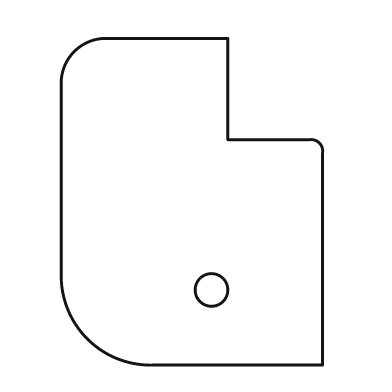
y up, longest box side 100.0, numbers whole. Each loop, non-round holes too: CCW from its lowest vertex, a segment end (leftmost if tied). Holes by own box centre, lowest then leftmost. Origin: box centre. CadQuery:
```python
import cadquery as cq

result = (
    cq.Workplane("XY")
    .moveTo(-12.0, -50.0)
    .lineTo(40.0, -50.0)
    .lineTo(40.0, 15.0)
    .threePointArc((39.0, 18.0), (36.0, 19.0))
    .lineTo(11.0, 19.0)
    .lineTo(11.0, 50.0)
    .lineTo(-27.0, 50.0)
    .threePointArc((-36.0, 46.0), (-40.0, 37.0))
    .lineTo(-40.0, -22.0)
    .threePointArc((-32.0, -42.0), (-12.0, -50.0))
    .close()
    .moveTo(6.0, -27.0)
    .circle(5.0)
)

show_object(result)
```